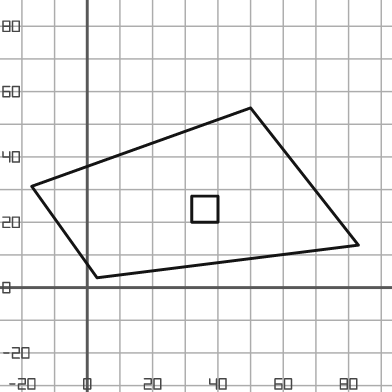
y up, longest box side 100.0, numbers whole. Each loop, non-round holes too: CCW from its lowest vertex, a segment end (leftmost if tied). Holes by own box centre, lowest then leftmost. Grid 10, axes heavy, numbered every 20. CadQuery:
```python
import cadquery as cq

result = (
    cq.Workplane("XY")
    .moveTo(3.0, 3.0)
    .lineTo(83.0, 13.0)
    .lineTo(50.0, 55.0)
    .lineTo(-17.0, 31.0)
    .close()
    .moveTo(32.0, 20.0)
    .lineTo(40.0, 20.0)
    .lineTo(40.0, 28.0)
    .lineTo(32.0, 28.0)
    .close()
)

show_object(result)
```